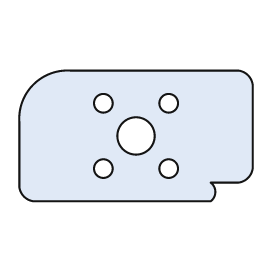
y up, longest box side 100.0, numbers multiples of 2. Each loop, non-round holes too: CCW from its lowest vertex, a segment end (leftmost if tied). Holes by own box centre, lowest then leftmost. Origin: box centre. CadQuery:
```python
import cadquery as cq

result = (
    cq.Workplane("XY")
    .moveTo(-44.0, -28.0)
    .lineTo(32.0, -28.0)
    .threePointArc((34.0, -24.0), (32.0, -20.0))
    .lineTo(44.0, -20.0)
    .threePointArc((48.0, -18.0), (50.0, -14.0))
    .lineTo(50.0, 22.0)
    .threePointArc((48.0, 26.0), (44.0, 28.0))
    .lineTo(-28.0, 28.0)
    .threePointArc((-44.0, 22.0), (-50.0, 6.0))
    .lineTo(-50.0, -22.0)
    .threePointArc((-48.0, -26.0), (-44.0, -28.0))
    .close()
    .moveTo(-14.0, -14.0)
    .circle(4.0)
    .moveTo(14.0, -14.0)
    .circle(4.0)
    .moveTo(0.0, 0.0)
    .circle(8.0)
    .moveTo(-14.0, 14.0)
    .circle(4.0)
    .moveTo(14.0, 14.0)
    .circle(4.0)
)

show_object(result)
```